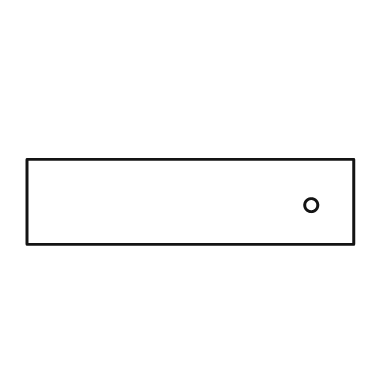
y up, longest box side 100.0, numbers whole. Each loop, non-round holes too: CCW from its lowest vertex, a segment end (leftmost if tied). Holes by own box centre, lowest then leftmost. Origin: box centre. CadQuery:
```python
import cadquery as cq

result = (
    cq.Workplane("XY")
    .moveTo(-50.0, -13.0)
    .lineTo(50.0, -13.0)
    .lineTo(50.0, 13.0)
    .lineTo(-50.0, 13.0)
    .close()
    .moveTo(37.0, -1.0)
    .circle(2.0)
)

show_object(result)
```